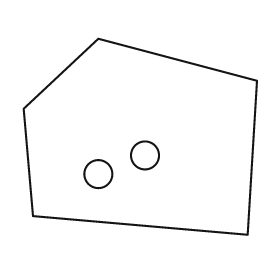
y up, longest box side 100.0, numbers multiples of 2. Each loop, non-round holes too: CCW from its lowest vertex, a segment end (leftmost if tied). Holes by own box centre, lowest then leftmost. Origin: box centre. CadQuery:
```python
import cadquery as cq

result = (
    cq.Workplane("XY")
    .moveTo(46.0, -42.0)
    .lineTo(50.0, 24.0)
    .lineTo(-18.0, 42.0)
    .lineTo(-50.0, 12.0)
    .lineTo(-46.0, -34.0)
    .close()
    .moveTo(-18.0, -16.0)
    .circle(6.0)
    .moveTo(2.0, -8.0)
    .circle(6.0)
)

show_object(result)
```